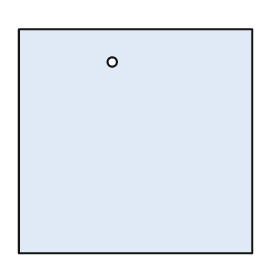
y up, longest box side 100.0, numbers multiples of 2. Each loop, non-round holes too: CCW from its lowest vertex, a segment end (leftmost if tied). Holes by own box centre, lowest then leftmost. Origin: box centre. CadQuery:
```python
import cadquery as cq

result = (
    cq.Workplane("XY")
    .moveTo(-50.0, -48.0)
    .lineTo(50.0, -48.0)
    .lineTo(50.0, 48.0)
    .lineTo(-50.0, 48.0)
    .close()
    .moveTo(-10.0, 34.0)
    .circle(2.0)
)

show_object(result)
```